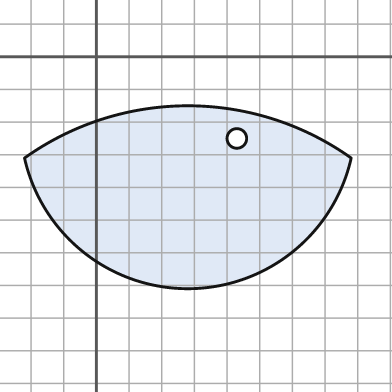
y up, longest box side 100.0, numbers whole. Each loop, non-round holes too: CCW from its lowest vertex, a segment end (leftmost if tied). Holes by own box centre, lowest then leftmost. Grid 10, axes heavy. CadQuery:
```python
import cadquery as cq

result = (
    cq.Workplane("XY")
    .moveTo(-22.0, -31.0)
    .threePointArc((28.0, -71.0), (78.0, -31.0))
    .threePointArc((28.0, -15.0), (-22.0, -31.0))
    .close()
    .moveTo(43.0, -25.0)
    .circle(3.0)
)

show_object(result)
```